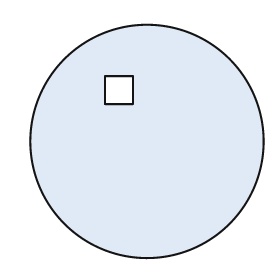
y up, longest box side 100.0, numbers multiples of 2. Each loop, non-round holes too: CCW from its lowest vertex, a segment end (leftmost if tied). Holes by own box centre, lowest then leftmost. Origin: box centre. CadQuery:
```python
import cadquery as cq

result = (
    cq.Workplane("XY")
    .moveTo(0.0, 0.0)
    .circle(50.0)
    .moveTo(-18.0, 16.0)
    .lineTo(-6.0, 16.0)
    .lineTo(-6.0, 28.0)
    .lineTo(-18.0, 28.0)
    .close()
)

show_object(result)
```